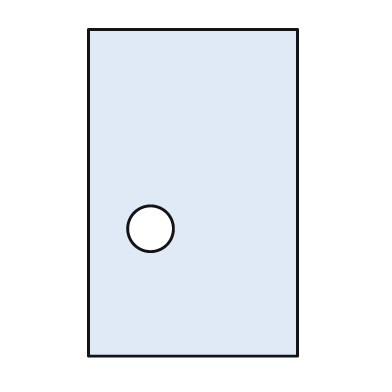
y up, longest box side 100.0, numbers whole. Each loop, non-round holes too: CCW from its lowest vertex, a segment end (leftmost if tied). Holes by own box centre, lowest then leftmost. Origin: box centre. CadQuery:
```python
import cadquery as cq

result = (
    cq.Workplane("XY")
    .moveTo(-32.0, -50.0)
    .lineTo(32.0, -50.0)
    .lineTo(32.0, 50.0)
    .lineTo(-32.0, 50.0)
    .close()
    .moveTo(-13.0, -11.0)
    .circle(7.0)
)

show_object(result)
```